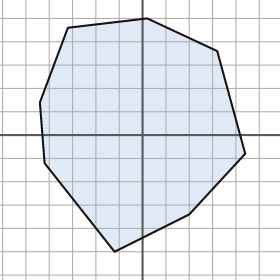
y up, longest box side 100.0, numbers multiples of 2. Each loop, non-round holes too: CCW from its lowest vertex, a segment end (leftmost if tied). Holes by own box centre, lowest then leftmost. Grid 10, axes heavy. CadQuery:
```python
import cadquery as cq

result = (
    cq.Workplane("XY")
    .moveTo(-12.0, -50.0)
    .lineTo(20.0, -34.0)
    .lineTo(44.0, -8.0)
    .lineTo(32.0, 36.0)
    .lineTo(2.0, 50.0)
    .lineTo(-32.0, 46.0)
    .lineTo(-44.0, 14.0)
    .lineTo(-42.0, -12.0)
    .close()
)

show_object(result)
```